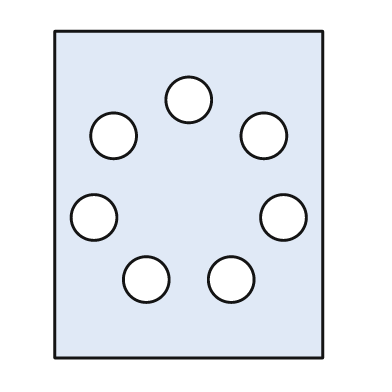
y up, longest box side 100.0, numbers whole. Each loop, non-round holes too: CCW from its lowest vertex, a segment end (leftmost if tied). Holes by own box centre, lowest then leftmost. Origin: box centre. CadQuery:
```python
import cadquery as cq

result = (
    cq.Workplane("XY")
    .moveTo(-41.0, -50.0)
    .lineTo(41.0, -50.0)
    .lineTo(41.0, 50.0)
    .lineTo(-41.0, 50.0)
    .close()
    .moveTo(-13.0, -26.0)
    .circle(7.0)
    .moveTo(13.0, -26.0)
    .circle(7.0)
    .moveTo(-29.0, -7.0)
    .circle(7.0)
    .moveTo(29.0, -7.0)
    .circle(7.0)
    .moveTo(-23.0, 18.0)
    .circle(7.0)
    .moveTo(23.0, 18.0)
    .circle(7.0)
    .moveTo(0.0, 29.0)
    .circle(7.0)
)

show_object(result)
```